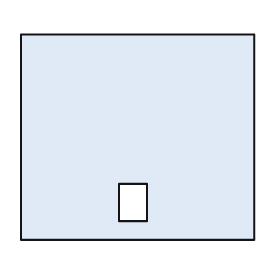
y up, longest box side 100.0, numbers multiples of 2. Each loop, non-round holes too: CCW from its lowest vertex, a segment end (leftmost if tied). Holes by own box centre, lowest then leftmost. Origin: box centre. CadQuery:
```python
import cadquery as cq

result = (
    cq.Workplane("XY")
    .moveTo(-50.0, -44.0)
    .lineTo(50.0, -44.0)
    .lineTo(50.0, 44.0)
    .lineTo(-50.0, 44.0)
    .close()
    .moveTo(-8.0, -36.0)
    .lineTo(4.0, -36.0)
    .lineTo(4.0, -20.0)
    .lineTo(-8.0, -20.0)
    .close()
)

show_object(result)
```